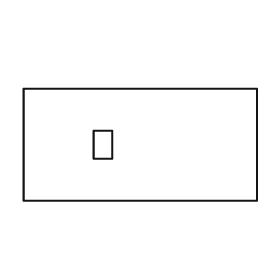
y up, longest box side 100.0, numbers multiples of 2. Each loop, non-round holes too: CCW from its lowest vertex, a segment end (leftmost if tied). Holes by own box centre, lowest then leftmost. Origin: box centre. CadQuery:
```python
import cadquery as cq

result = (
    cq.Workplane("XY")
    .moveTo(-50.0, -24.0)
    .lineTo(50.0, -24.0)
    .lineTo(50.0, 24.0)
    .lineTo(-50.0, 24.0)
    .close()
    .moveTo(-20.0, -6.0)
    .lineTo(-12.0, -6.0)
    .lineTo(-12.0, 6.0)
    .lineTo(-20.0, 6.0)
    .close()
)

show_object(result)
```